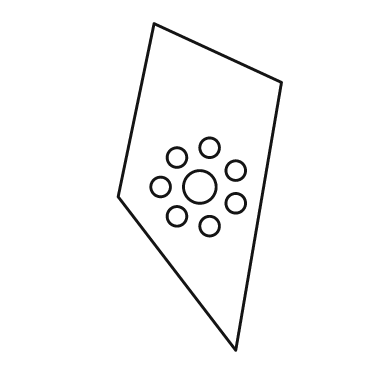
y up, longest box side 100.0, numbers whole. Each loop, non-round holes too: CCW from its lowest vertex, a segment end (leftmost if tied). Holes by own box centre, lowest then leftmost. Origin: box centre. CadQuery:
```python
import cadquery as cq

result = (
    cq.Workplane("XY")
    .moveTo(11.0, -50.0)
    .lineTo(25.0, 32.0)
    .lineTo(-14.0, 50.0)
    .lineTo(-25.0, -3.0)
    .close()
    .moveTo(3.0, -12.0)
    .circle(3.0)
    .moveTo(-7.0, -9.0)
    .circle(3.0)
    .moveTo(11.0, -5.0)
    .circle(3.0)
    .moveTo(-12.0, 0.0)
    .circle(3.0)
    .moveTo(0.0, 0.0)
    .circle(5.0)
    .moveTo(11.0, 5.0)
    .circle(3.0)
    .moveTo(-7.0, 9.0)
    .circle(3.0)
    .moveTo(3.0, 12.0)
    .circle(3.0)
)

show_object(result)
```